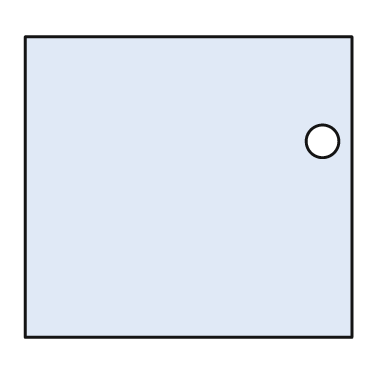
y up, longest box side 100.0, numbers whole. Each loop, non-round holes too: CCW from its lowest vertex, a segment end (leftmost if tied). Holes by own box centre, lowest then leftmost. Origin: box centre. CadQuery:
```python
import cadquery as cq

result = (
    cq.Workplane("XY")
    .moveTo(-50.0, -46.0)
    .lineTo(50.0, -46.0)
    .lineTo(50.0, 46.0)
    .lineTo(-50.0, 46.0)
    .close()
    .moveTo(41.0, 14.0)
    .circle(5.0)
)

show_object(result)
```